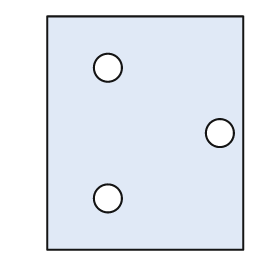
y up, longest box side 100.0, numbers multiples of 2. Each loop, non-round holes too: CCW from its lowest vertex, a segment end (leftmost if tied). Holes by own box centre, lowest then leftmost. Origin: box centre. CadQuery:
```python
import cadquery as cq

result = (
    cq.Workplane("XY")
    .moveTo(-42.0, -50.0)
    .lineTo(42.0, -50.0)
    .lineTo(42.0, 50.0)
    .lineTo(-42.0, 50.0)
    .close()
    .moveTo(-16.0, -28.0)
    .circle(6.0)
    .moveTo(32.0, 0.0)
    .circle(6.0)
    .moveTo(-16.0, 28.0)
    .circle(6.0)
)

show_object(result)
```